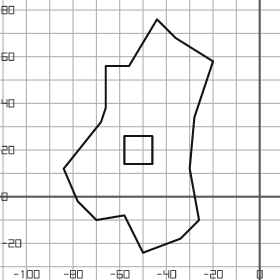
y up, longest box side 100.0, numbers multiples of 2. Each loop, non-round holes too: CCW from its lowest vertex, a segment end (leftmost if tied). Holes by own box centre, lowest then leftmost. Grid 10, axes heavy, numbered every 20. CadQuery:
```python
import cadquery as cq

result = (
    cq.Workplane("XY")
    .moveTo(-50.0, -24.0)
    .lineTo(-34.0, -18.0)
    .lineTo(-26.0, -10.0)
    .lineTo(-30.0, 12.0)
    .lineTo(-28.0, 34.0)
    .lineTo(-20.0, 58.0)
    .lineTo(-36.0, 68.0)
    .lineTo(-44.0, 76.0)
    .lineTo(-56.0, 56.0)
    .lineTo(-66.0, 56.0)
    .lineTo(-66.0, 38.0)
    .lineTo(-68.0, 32.0)
    .lineTo(-84.0, 12.0)
    .lineTo(-78.0, -2.0)
    .lineTo(-70.0, -10.0)
    .lineTo(-58.0, -8.0)
    .close()
    .moveTo(-58.0, 14.0)
    .lineTo(-46.0, 14.0)
    .lineTo(-46.0, 26.0)
    .lineTo(-58.0, 26.0)
    .close()
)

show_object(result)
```